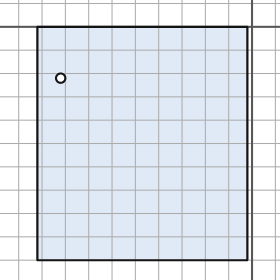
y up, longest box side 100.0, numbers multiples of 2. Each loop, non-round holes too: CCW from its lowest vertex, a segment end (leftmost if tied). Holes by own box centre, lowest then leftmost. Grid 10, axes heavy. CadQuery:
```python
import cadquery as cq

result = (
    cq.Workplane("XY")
    .moveTo(-92.0, -100.0)
    .lineTo(-2.0, -100.0)
    .lineTo(-2.0, 0.0)
    .lineTo(-92.0, 0.0)
    .close()
    .moveTo(-82.0, -22.0)
    .circle(2.0)
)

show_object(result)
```